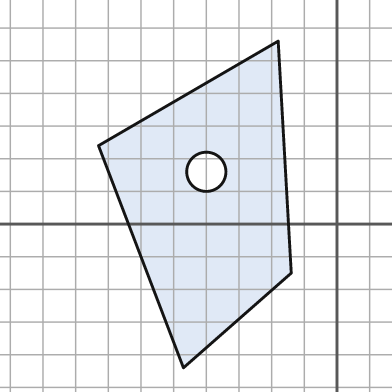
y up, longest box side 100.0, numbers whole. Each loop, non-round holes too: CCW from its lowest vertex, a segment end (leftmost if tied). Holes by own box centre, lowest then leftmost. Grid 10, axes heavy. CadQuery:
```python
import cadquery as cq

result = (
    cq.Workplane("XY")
    .moveTo(-47.0, -44.0)
    .lineTo(-14.0, -15.0)
    .lineTo(-18.0, 56.0)
    .lineTo(-73.0, 24.0)
    .close()
    .moveTo(-40.0, 16.0)
    .circle(6.0)
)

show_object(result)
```